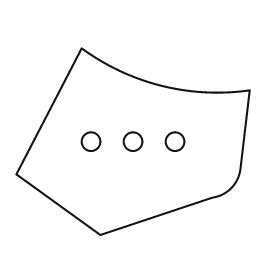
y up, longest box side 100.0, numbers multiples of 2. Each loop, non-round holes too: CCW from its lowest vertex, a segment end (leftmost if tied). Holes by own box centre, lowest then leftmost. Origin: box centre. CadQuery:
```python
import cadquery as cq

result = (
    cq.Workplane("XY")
    .moveTo(-14.0, -40.0)
    .lineTo(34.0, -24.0)
    .threePointArc((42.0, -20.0), (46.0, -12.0))
    .lineTo(50.0, 22.0)
    .threePointArc((12.0, 24.0), (-22.0, 40.0))
    .lineTo(-50.0, -14.0)
    .close()
    .moveTo(-18.0, 0.0)
    .circle(4.0)
    .moveTo(0.0, 0.0)
    .circle(4.0)
    .moveTo(18.0, 0.0)
    .circle(4.0)
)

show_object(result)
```